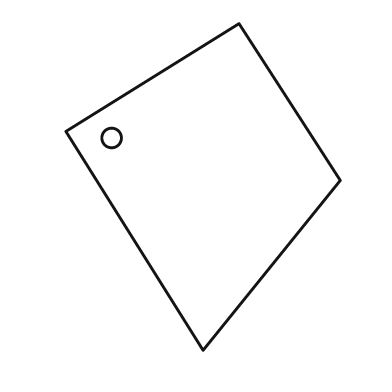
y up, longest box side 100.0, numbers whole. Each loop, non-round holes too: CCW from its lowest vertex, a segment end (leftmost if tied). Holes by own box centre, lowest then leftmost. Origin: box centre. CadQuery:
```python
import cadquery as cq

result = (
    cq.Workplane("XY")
    .moveTo(0.0, -50.0)
    .lineTo(42.0, 2.0)
    .lineTo(11.0, 50.0)
    .lineTo(-42.0, 17.0)
    .close()
    .moveTo(-28.0, 15.0)
    .circle(3.0)
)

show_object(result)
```